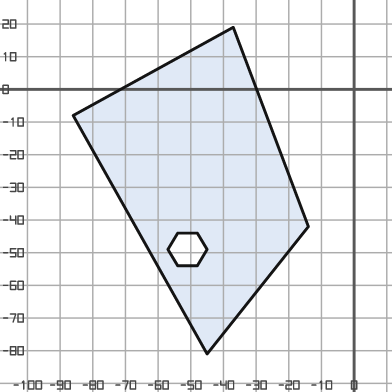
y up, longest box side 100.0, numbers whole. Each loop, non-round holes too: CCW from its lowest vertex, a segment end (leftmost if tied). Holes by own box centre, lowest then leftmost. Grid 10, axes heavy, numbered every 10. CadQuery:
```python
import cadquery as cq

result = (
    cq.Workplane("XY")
    .moveTo(-45.0, -81.0)
    .lineTo(-14.0, -42.0)
    .lineTo(-37.0, 19.0)
    .lineTo(-86.0, -8.0)
    .close()
    .moveTo(-54.0, -54.0)
    .lineTo(-48.0, -54.0)
    .lineTo(-45.0, -49.0)
    .lineTo(-48.0, -44.0)
    .lineTo(-54.0, -44.0)
    .lineTo(-57.0, -49.0)
    .close()
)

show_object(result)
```